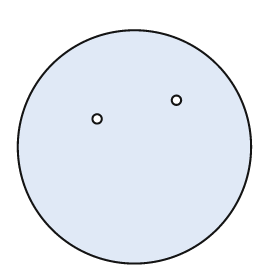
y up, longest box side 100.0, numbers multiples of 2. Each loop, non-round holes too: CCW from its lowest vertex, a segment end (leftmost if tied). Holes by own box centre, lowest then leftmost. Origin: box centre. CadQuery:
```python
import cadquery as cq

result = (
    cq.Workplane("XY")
    .moveTo(0.0, 0.0)
    .circle(50.0)
    .moveTo(-16.0, 12.0)
    .circle(2.0)
    .moveTo(18.0, 20.0)
    .circle(2.0)
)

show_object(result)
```